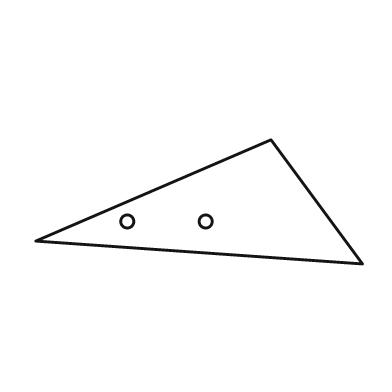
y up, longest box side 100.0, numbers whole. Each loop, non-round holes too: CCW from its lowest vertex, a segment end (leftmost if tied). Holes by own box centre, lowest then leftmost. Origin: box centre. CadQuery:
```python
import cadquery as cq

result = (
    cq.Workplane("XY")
    .moveTo(50.0, -19.0)
    .lineTo(22.0, 19.0)
    .lineTo(-50.0, -12.0)
    .close()
    .moveTo(-22.0, -6.0)
    .circle(2.0)
    .moveTo(2.0, -6.0)
    .circle(2.0)
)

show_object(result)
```